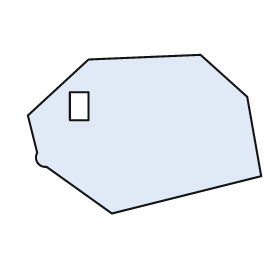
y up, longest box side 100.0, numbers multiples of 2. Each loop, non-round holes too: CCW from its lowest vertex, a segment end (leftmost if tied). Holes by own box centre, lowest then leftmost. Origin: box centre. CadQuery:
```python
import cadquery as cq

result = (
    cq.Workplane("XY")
    .moveTo(-14.0, -34.0)
    .lineTo(50.0, -18.0)
    .lineTo(44.0, 16.0)
    .lineTo(24.0, 34.0)
    .lineTo(-24.0, 32.0)
    .lineTo(-50.0, 8.0)
    .lineTo(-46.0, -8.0)
    .threePointArc((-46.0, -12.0), (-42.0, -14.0))
    .close()
    .moveTo(-32.0, 6.0)
    .lineTo(-24.0, 6.0)
    .lineTo(-24.0, 18.0)
    .lineTo(-32.0, 18.0)
    .close()
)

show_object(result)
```